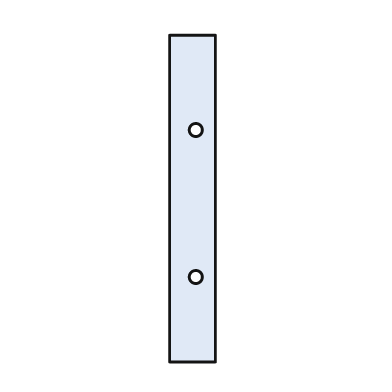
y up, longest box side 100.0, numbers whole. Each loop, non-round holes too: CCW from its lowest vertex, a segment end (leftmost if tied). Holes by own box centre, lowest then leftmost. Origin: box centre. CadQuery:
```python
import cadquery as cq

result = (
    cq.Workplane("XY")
    .moveTo(-7.0, -50.0)
    .lineTo(7.0, -50.0)
    .lineTo(7.0, 50.0)
    .lineTo(-7.0, 50.0)
    .close()
    .moveTo(1.0, -24.0)
    .circle(2.0)
    .moveTo(1.0, 21.0)
    .circle(2.0)
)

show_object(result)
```